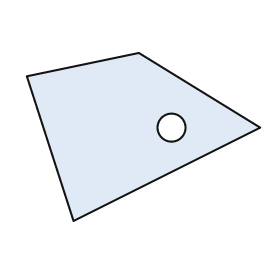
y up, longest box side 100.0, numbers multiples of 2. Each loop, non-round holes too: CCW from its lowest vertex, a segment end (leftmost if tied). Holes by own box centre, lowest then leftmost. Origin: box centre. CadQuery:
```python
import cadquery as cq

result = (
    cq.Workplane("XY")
    .moveTo(-30.0, -36.0)
    .lineTo(50.0, 4.0)
    .lineTo(-2.0, 36.0)
    .lineTo(-50.0, 26.0)
    .close()
    .moveTo(12.0, 4.0)
    .circle(6.0)
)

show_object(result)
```